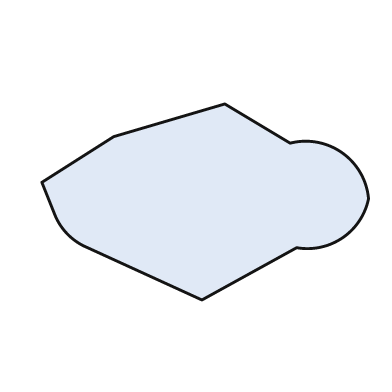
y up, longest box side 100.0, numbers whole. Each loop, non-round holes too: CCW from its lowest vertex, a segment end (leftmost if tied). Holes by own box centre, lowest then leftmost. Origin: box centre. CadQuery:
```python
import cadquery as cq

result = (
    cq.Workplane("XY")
    .moveTo(-1.0, -30.0)
    .lineTo(28.0, -14.0)
    .threePointArc((42.0, -11.0), (50.0, 1.0))
    .threePointArc((42.0, 15.0), (26.0, 18.0))
    .lineTo(6.0, 30.0)
    .lineTo(-28.0, 20.0)
    .lineTo(-50.0, 6.0)
    .lineTo(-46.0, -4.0)
    .threePointArc((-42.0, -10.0), (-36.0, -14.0))
    .close()
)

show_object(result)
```